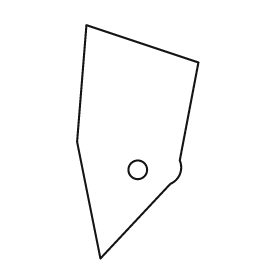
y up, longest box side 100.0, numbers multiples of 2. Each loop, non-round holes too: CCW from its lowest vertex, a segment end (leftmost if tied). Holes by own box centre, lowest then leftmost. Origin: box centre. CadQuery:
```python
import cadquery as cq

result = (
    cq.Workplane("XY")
    .moveTo(-16.0, -50.0)
    .lineTo(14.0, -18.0)
    .threePointArc((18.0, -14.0), (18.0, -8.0))
    .lineTo(26.0, 34.0)
    .lineTo(-22.0, 50.0)
    .lineTo(-26.0, 0.0)
    .close()
    .moveTo(0.0, -12.0)
    .circle(4.0)
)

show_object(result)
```